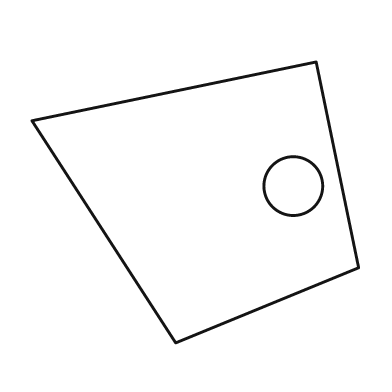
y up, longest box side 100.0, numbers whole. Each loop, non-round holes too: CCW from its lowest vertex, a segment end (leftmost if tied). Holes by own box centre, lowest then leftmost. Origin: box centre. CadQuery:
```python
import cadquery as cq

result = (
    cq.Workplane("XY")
    .moveTo(-6.0, -43.0)
    .lineTo(50.0, -20.0)
    .lineTo(37.0, 43.0)
    .lineTo(-50.0, 25.0)
    .close()
    .moveTo(30.0, 5.0)
    .circle(9.0)
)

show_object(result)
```